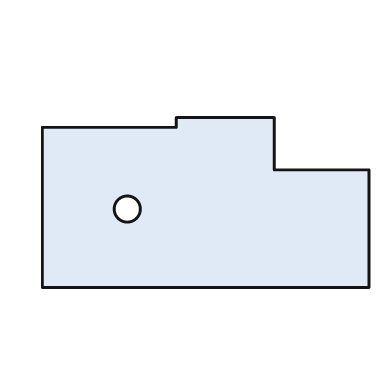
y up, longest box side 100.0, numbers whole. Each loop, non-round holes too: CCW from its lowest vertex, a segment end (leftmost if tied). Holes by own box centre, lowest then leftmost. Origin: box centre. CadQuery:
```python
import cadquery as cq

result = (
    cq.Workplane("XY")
    .moveTo(-50.0, -26.0)
    .lineTo(50.0, -26.0)
    .lineTo(50.0, 10.0)
    .lineTo(21.0, 10.0)
    .lineTo(21.0, 26.0)
    .lineTo(-9.0, 26.0)
    .lineTo(-9.0, 23.0)
    .lineTo(-50.0, 23.0)
    .close()
    .moveTo(-24.0, -2.0)
    .circle(4.0)
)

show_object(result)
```